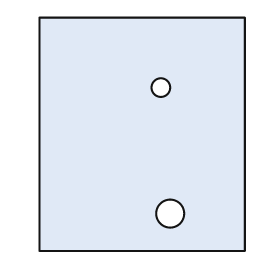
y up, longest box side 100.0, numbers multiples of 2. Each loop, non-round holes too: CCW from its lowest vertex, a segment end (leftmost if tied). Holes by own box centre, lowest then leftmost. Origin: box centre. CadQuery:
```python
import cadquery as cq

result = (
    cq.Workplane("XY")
    .moveTo(-44.0, -50.0)
    .lineTo(44.0, -50.0)
    .lineTo(44.0, 50.0)
    .lineTo(-44.0, 50.0)
    .close()
    .moveTo(12.0, -34.0)
    .circle(6.0)
    .moveTo(8.0, 20.0)
    .circle(4.0)
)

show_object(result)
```